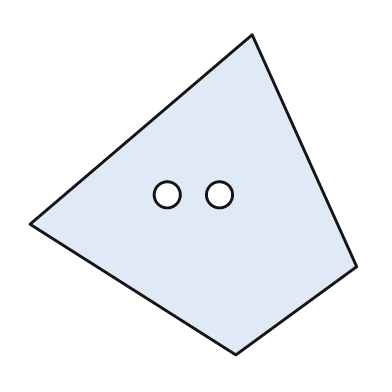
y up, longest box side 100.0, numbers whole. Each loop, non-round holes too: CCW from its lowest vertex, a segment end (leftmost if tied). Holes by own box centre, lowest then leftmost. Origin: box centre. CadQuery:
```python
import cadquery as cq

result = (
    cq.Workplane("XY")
    .moveTo(13.0, -49.0)
    .lineTo(50.0, -22.0)
    .lineTo(18.0, 49.0)
    .lineTo(-50.0, -9.0)
    .close()
    .moveTo(-8.0, 0.0)
    .circle(4.0)
    .moveTo(8.0, 0.0)
    .circle(4.0)
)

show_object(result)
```